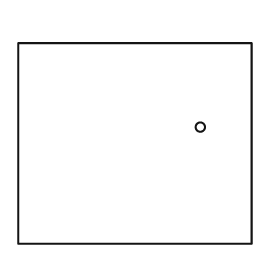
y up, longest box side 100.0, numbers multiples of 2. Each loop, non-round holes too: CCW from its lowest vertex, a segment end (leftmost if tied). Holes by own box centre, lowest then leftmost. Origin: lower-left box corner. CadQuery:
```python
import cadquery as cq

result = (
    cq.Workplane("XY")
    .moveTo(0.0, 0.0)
    .lineTo(100.0, 0.0)
    .lineTo(100.0, 86.0)
    .lineTo(0.0, 86.0)
    .close()
    .moveTo(78.0, 50.0)
    .circle(2.0)
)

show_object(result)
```